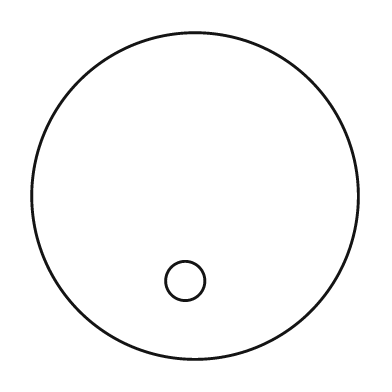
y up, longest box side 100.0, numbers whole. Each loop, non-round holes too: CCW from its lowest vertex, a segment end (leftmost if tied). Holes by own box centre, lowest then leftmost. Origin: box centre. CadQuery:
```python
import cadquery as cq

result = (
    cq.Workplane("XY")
    .moveTo(0.0, 0.0)
    .circle(50.0)
    .moveTo(-3.0, -26.0)
    .circle(6.0)
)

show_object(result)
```